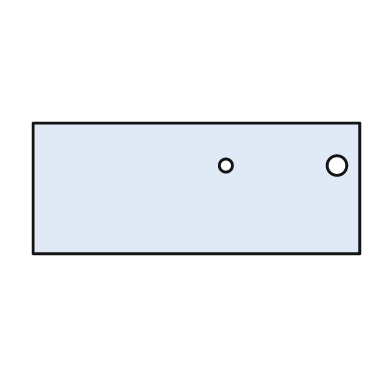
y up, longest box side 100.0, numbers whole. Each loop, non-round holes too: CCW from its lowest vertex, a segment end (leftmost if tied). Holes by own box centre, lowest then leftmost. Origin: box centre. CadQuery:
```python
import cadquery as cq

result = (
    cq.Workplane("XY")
    .moveTo(-50.0, -20.0)
    .lineTo(50.0, -20.0)
    .lineTo(50.0, 20.0)
    .lineTo(-50.0, 20.0)
    .close()
    .moveTo(9.0, 7.0)
    .circle(2.0)
    .moveTo(43.0, 7.0)
    .circle(3.0)
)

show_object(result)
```